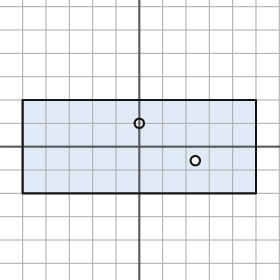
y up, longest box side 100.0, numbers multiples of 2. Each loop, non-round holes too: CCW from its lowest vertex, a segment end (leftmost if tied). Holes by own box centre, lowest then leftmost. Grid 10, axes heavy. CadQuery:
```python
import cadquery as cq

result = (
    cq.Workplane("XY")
    .moveTo(-50.0, -20.0)
    .lineTo(50.0, -20.0)
    .lineTo(50.0, 20.0)
    .lineTo(-50.0, 20.0)
    .close()
    .moveTo(24.0, -6.0)
    .circle(2.0)
    .moveTo(0.0, 10.0)
    .circle(2.0)
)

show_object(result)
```